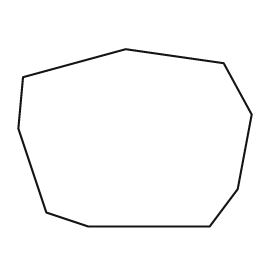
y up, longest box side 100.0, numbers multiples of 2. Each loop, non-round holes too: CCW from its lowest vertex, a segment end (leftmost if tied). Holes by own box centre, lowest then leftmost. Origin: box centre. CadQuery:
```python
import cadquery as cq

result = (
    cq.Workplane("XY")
    .moveTo(-20.0, -38.0)
    .lineTo(32.0, -38.0)
    .lineTo(44.0, -22.0)
    .lineTo(50.0, 10.0)
    .lineTo(38.0, 32.0)
    .lineTo(-4.0, 38.0)
    .lineTo(-48.0, 26.0)
    .lineTo(-50.0, 4.0)
    .lineTo(-38.0, -32.0)
    .close()
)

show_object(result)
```